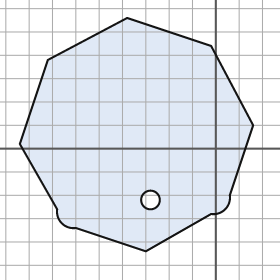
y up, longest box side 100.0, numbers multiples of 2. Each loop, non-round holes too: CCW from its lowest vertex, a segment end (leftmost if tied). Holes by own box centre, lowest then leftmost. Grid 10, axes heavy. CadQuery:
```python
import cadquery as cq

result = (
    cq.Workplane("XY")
    .moveTo(-30.0, -44.0)
    .lineTo(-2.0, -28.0)
    .threePointArc((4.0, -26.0), (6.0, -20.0))
    .lineTo(16.0, 10.0)
    .lineTo(-2.0, 44.0)
    .lineTo(-38.0, 56.0)
    .lineTo(-72.0, 38.0)
    .lineTo(-84.0, 2.0)
    .lineTo(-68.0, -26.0)
    .threePointArc((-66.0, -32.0), (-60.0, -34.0))
    .close()
    .moveTo(-28.0, -22.0)
    .circle(4.0)
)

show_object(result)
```